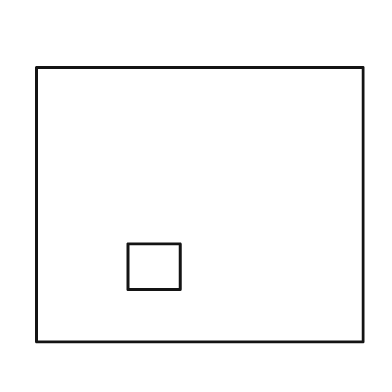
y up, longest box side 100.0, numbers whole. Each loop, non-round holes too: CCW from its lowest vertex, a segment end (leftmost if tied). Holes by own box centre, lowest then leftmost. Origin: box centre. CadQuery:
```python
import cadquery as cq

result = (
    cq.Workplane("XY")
    .moveTo(-50.0, -42.0)
    .lineTo(50.0, -42.0)
    .lineTo(50.0, 42.0)
    .lineTo(-50.0, 42.0)
    .close()
    .moveTo(-22.0, -26.0)
    .lineTo(-6.0, -26.0)
    .lineTo(-6.0, -12.0)
    .lineTo(-22.0, -12.0)
    .close()
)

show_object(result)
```